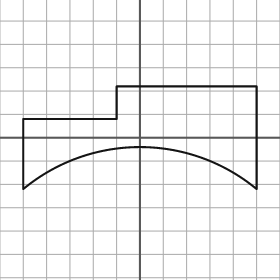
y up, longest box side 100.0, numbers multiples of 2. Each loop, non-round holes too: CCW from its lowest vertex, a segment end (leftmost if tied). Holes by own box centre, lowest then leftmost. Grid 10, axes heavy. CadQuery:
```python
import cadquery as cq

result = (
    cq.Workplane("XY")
    .moveTo(-50.0, -22.0)
    .threePointArc((0.0, -4.0), (50.0, -22.0))
    .lineTo(50.0, 22.0)
    .lineTo(-10.0, 22.0)
    .lineTo(-10.0, 8.0)
    .lineTo(-50.0, 8.0)
    .close()
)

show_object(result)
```